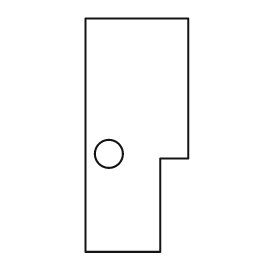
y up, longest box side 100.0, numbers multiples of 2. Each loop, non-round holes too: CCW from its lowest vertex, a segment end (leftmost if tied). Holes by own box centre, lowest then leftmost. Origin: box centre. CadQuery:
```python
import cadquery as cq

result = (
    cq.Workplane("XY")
    .moveTo(-22.0, -50.0)
    .lineTo(10.0, -50.0)
    .lineTo(10.0, -10.0)
    .lineTo(22.0, -10.0)
    .lineTo(22.0, 50.0)
    .lineTo(-22.0, 50.0)
    .close()
    .moveTo(-12.0, -8.0)
    .circle(6.0)
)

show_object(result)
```